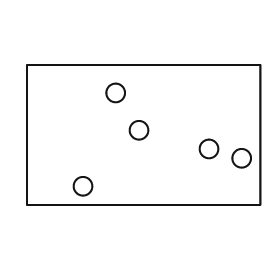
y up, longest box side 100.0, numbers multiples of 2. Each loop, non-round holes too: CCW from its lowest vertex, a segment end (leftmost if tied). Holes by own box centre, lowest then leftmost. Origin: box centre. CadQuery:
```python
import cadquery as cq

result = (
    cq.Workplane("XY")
    .moveTo(-50.0, -30.0)
    .lineTo(50.0, -30.0)
    .lineTo(50.0, 30.0)
    .lineTo(-50.0, 30.0)
    .close()
    .moveTo(-26.0, -22.0)
    .circle(4.0)
    .moveTo(42.0, -10.0)
    .circle(4.0)
    .moveTo(28.0, -6.0)
    .circle(4.0)
    .moveTo(-2.0, 2.0)
    .circle(4.0)
    .moveTo(-12.0, 18.0)
    .circle(4.0)
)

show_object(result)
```